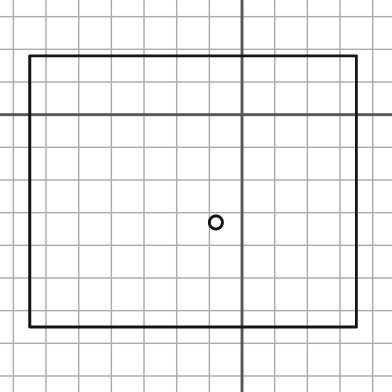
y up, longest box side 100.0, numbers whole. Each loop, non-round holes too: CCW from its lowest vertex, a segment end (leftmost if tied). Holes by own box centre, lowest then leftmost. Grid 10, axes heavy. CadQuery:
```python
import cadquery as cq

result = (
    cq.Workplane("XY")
    .moveTo(-65.0, -65.0)
    .lineTo(35.0, -65.0)
    .lineTo(35.0, 18.0)
    .lineTo(-65.0, 18.0)
    .close()
    .moveTo(-8.0, -33.0)
    .circle(2.0)
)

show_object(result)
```